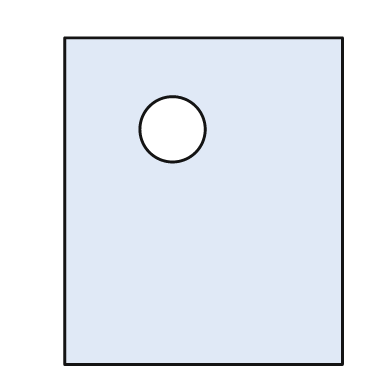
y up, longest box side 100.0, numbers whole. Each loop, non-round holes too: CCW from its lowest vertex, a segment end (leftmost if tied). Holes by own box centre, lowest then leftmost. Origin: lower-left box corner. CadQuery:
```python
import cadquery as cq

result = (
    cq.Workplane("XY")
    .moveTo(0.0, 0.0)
    .lineTo(85.0, 0.0)
    .lineTo(85.0, 100.0)
    .lineTo(0.0, 100.0)
    .close()
    .moveTo(33.0, 72.0)
    .circle(10.0)
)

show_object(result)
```